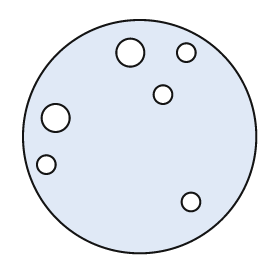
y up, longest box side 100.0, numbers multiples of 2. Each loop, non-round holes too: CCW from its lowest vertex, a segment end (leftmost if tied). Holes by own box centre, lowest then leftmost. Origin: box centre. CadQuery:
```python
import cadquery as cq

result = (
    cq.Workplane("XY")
    .moveTo(0.0, 0.0)
    .circle(50.0)
    .moveTo(22.0, -28.0)
    .circle(4.0)
    .moveTo(-40.0, -12.0)
    .circle(4.0)
    .moveTo(-36.0, 8.0)
    .circle(6.0)
    .moveTo(10.0, 18.0)
    .circle(4.0)
    .moveTo(-4.0, 36.0)
    .circle(6.0)
    .moveTo(20.0, 36.0)
    .circle(4.0)
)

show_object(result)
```